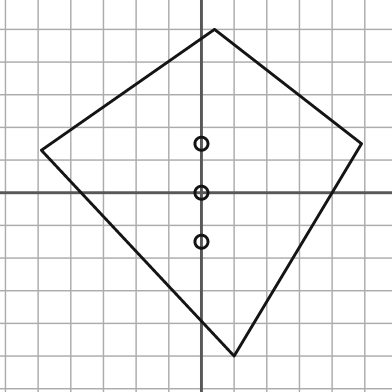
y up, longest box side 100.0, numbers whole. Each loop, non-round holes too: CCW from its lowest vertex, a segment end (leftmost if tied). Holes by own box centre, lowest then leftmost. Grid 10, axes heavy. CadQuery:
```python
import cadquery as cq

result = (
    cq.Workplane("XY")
    .moveTo(10.0, -50.0)
    .lineTo(49.0, 15.0)
    .lineTo(4.0, 50.0)
    .lineTo(-49.0, 13.0)
    .close()
    .moveTo(0.0, -15.0)
    .circle(2.0)
    .moveTo(0.0, 0.0)
    .circle(2.0)
    .moveTo(0.0, 15.0)
    .circle(2.0)
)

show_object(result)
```